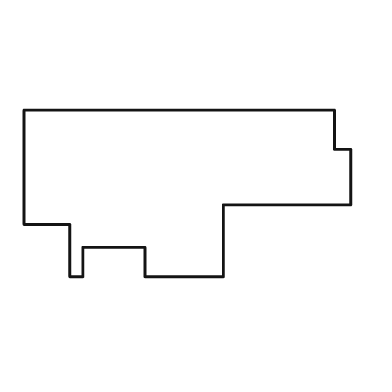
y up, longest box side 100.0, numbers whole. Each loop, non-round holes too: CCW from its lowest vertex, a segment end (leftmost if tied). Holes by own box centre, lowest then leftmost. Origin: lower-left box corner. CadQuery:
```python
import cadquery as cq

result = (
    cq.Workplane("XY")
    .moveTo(14.0, 0.0)
    .lineTo(18.0, 0.0)
    .lineTo(18.0, 9.0)
    .lineTo(37.0, 9.0)
    .lineTo(37.0, 0.0)
    .lineTo(61.0, 0.0)
    .lineTo(61.0, 22.0)
    .lineTo(100.0, 22.0)
    .lineTo(100.0, 39.0)
    .lineTo(95.0, 39.0)
    .lineTo(95.0, 51.0)
    .lineTo(0.0, 51.0)
    .lineTo(0.0, 16.0)
    .lineTo(14.0, 16.0)
    .close()
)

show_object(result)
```